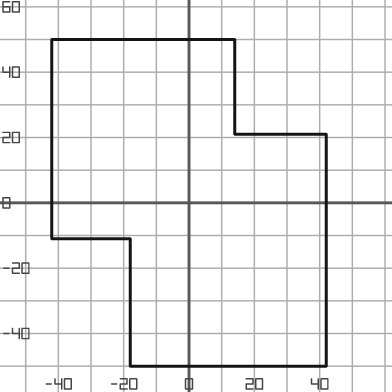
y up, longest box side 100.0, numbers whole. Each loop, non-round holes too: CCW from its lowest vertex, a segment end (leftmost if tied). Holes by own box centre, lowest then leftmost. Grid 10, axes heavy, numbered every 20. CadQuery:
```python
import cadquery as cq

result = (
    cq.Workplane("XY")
    .moveTo(-18.0, -50.0)
    .lineTo(42.0, -50.0)
    .lineTo(42.0, 21.0)
    .lineTo(14.0, 21.0)
    .lineTo(14.0, 50.0)
    .lineTo(-42.0, 50.0)
    .lineTo(-42.0, -11.0)
    .lineTo(-18.0, -11.0)
    .close()
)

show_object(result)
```